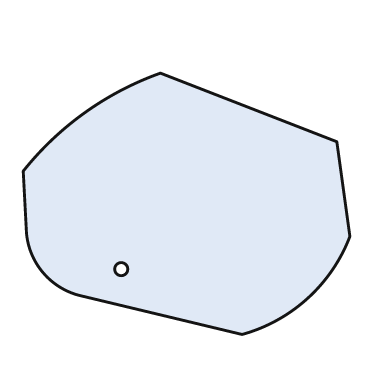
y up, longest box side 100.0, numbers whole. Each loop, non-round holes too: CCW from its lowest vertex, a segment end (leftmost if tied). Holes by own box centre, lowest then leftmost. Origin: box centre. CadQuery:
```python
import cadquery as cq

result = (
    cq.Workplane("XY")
    .moveTo(17.0, -40.0)
    .threePointArc((37.0, -29.0), (50.0, -10.0))
    .lineTo(46.0, 19.0)
    .lineTo(-8.0, 40.0)
    .threePointArc((-31.0, 28.0), (-50.0, 10.0))
    .lineTo(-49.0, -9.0)
    .threePointArc((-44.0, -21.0), (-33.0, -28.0))
    .close()
    .moveTo(-20.0, -20.0)
    .circle(2.0)
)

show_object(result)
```